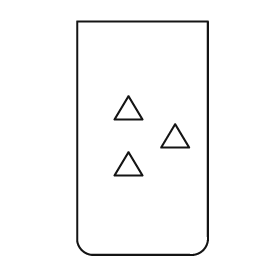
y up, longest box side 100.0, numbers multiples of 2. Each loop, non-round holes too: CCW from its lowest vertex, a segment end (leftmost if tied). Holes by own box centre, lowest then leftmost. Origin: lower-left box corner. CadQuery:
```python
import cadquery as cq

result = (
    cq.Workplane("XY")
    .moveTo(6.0, 0.0)
    .lineTo(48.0, 0.0)
    .threePointArc((54.0, 2.0), (56.0, 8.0))
    .lineTo(56.0, 100.0)
    .lineTo(0.0, 100.0)
    .lineTo(0.0, 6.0)
    .threePointArc((2.0, 2.0), (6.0, 0.0))
    .close()
    .moveTo(16.0, 34.0)
    .lineTo(28.0, 34.0)
    .lineTo(22.0, 44.0)
    .close()
    .moveTo(36.0, 46.0)
    .lineTo(48.0, 46.0)
    .lineTo(42.0, 56.0)
    .close()
    .moveTo(16.0, 58.0)
    .lineTo(28.0, 58.0)
    .lineTo(22.0, 68.0)
    .close()
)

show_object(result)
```